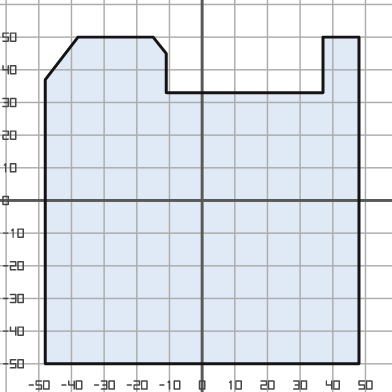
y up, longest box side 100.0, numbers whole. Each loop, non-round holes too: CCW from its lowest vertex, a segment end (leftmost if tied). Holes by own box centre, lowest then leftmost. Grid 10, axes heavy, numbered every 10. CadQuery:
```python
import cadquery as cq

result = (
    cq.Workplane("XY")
    .moveTo(-48.0, -50.0)
    .lineTo(48.0, -50.0)
    .lineTo(48.0, 50.0)
    .lineTo(37.0, 50.0)
    .lineTo(37.0, 33.0)
    .lineTo(-11.0, 33.0)
    .lineTo(-11.0, 45.0)
    .lineTo(-15.0, 50.0)
    .lineTo(-38.0, 50.0)
    .lineTo(-48.0, 37.0)
    .close()
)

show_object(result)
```